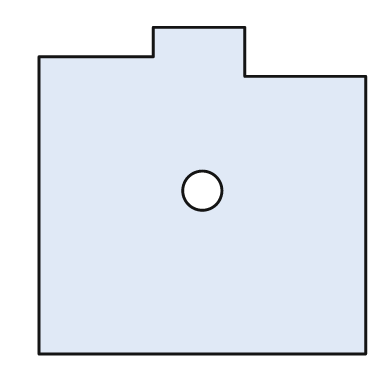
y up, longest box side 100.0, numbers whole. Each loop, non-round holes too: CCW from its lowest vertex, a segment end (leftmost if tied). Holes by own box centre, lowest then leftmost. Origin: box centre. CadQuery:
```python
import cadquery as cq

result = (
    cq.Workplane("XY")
    .moveTo(-50.0, -50.0)
    .lineTo(50.0, -50.0)
    .lineTo(50.0, 35.0)
    .lineTo(13.0, 35.0)
    .lineTo(13.0, 50.0)
    .lineTo(-15.0, 50.0)
    .lineTo(-15.0, 41.0)
    .lineTo(-50.0, 41.0)
    .close()
    .moveTo(0.0, 0.0)
    .circle(6.0)
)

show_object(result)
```